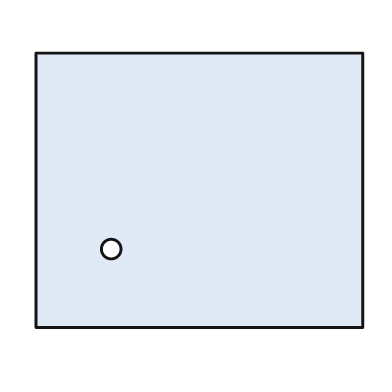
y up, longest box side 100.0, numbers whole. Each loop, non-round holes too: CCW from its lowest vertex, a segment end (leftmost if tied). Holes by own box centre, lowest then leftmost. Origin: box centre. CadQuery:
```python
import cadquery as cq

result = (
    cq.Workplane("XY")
    .moveTo(-50.0, -42.0)
    .lineTo(50.0, -42.0)
    .lineTo(50.0, 42.0)
    .lineTo(-50.0, 42.0)
    .close()
    .moveTo(-27.0, -18.0)
    .circle(3.0)
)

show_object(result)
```